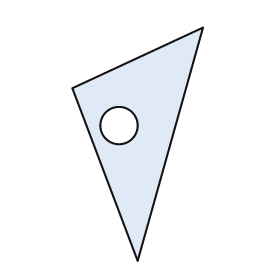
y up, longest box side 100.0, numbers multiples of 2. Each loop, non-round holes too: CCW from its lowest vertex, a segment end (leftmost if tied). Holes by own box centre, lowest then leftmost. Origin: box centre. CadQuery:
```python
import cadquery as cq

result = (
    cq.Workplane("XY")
    .moveTo(0.0, -50.0)
    .lineTo(28.0, 50.0)
    .lineTo(-28.0, 24.0)
    .close()
    .moveTo(-8.0, 8.0)
    .circle(8.0)
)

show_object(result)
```